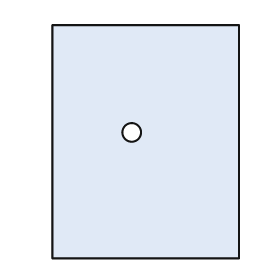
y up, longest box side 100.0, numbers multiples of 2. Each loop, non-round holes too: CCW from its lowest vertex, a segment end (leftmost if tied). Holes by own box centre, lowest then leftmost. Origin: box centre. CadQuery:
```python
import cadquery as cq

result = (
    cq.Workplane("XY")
    .moveTo(-40.0, -50.0)
    .lineTo(40.0, -50.0)
    .lineTo(40.0, 50.0)
    .lineTo(-40.0, 50.0)
    .close()
    .moveTo(-6.0, 4.0)
    .circle(4.0)
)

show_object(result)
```